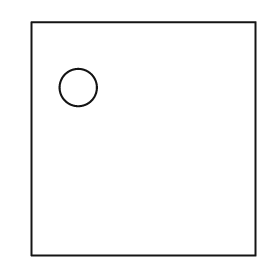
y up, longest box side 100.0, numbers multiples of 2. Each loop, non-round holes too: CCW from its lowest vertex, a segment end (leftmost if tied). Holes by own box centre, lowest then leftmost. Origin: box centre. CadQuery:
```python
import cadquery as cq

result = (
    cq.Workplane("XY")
    .moveTo(-48.0, -50.0)
    .lineTo(48.0, -50.0)
    .lineTo(48.0, 50.0)
    .lineTo(-48.0, 50.0)
    .close()
    .moveTo(-28.0, 22.0)
    .circle(8.0)
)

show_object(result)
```